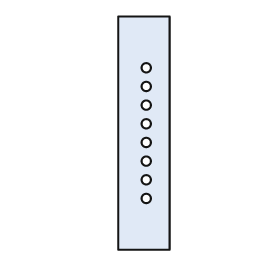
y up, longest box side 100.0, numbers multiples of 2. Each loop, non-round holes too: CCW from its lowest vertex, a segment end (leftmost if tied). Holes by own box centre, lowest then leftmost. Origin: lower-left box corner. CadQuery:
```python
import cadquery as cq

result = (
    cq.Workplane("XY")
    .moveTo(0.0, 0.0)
    .lineTo(22.0, 0.0)
    .lineTo(22.0, 100.0)
    .lineTo(0.0, 100.0)
    .close()
    .moveTo(12.0, 22.0)
    .circle(2.0)
    .moveTo(12.0, 30.0)
    .circle(2.0)
    .moveTo(12.0, 38.0)
    .circle(2.0)
    .moveTo(12.0, 46.0)
    .circle(2.0)
    .moveTo(12.0, 54.0)
    .circle(2.0)
    .moveTo(12.0, 62.0)
    .circle(2.0)
    .moveTo(12.0, 70.0)
    .circle(2.0)
    .moveTo(12.0, 78.0)
    .circle(2.0)
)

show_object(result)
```